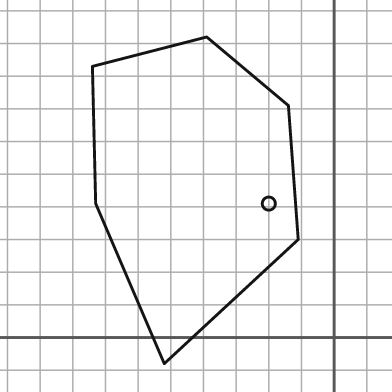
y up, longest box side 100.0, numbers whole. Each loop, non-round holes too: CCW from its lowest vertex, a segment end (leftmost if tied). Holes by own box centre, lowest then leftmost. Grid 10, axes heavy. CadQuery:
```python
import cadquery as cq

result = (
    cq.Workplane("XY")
    .moveTo(-52.0, -8.0)
    .lineTo(-11.0, 30.0)
    .lineTo(-14.0, 71.0)
    .lineTo(-39.0, 92.0)
    .lineTo(-74.0, 83.0)
    .lineTo(-73.0, 41.0)
    .close()
    .moveTo(-20.0, 41.0)
    .circle(2.0)
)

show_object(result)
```